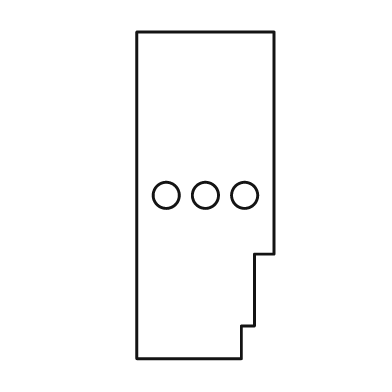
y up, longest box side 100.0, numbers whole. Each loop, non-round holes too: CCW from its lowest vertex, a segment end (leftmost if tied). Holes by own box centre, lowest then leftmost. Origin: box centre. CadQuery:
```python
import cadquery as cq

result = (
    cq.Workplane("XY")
    .moveTo(-21.0, -50.0)
    .lineTo(11.0, -50.0)
    .lineTo(11.0, -40.0)
    .lineTo(15.0, -40.0)
    .lineTo(15.0, -18.0)
    .lineTo(21.0, -18.0)
    .lineTo(21.0, 50.0)
    .lineTo(-21.0, 50.0)
    .close()
    .moveTo(-12.0, 0.0)
    .circle(4.0)
    .moveTo(0.0, 0.0)
    .circle(4.0)
    .moveTo(12.0, 0.0)
    .circle(4.0)
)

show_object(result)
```